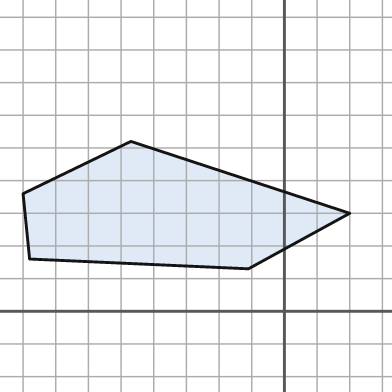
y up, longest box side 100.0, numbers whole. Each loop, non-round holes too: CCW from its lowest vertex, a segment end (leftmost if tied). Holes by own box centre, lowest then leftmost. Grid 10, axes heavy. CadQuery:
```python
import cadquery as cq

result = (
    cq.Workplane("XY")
    .moveTo(-11.0, 13.0)
    .lineTo(20.0, 30.0)
    .lineTo(-47.0, 52.0)
    .lineTo(-80.0, 36.0)
    .lineTo(-78.0, 16.0)
    .close()
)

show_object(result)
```